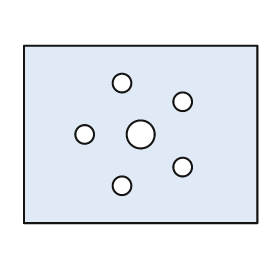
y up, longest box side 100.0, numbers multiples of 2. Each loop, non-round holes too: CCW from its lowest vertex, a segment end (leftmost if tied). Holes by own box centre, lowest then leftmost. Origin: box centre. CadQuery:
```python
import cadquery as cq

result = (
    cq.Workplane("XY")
    .moveTo(-50.0, -38.0)
    .lineTo(50.0, -38.0)
    .lineTo(50.0, 38.0)
    .lineTo(-50.0, 38.0)
    .close()
    .moveTo(-8.0, -22.0)
    .circle(4.0)
    .moveTo(18.0, -14.0)
    .circle(4.0)
    .moveTo(-24.0, 0.0)
    .circle(4.0)
    .moveTo(0.0, 0.0)
    .circle(6.0)
    .moveTo(18.0, 14.0)
    .circle(4.0)
    .moveTo(-8.0, 22.0)
    .circle(4.0)
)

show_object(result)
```